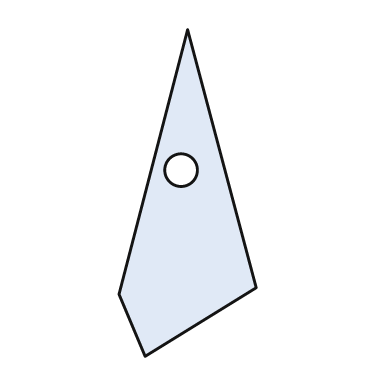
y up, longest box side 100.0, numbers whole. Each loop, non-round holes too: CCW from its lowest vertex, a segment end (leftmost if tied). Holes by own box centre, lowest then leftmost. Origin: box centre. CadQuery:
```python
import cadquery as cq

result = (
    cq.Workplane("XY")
    .moveTo(-13.0, -50.0)
    .lineTo(21.0, -29.0)
    .lineTo(0.0, 50.0)
    .lineTo(-21.0, -31.0)
    .close()
    .moveTo(-2.0, 7.0)
    .circle(5.0)
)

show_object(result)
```